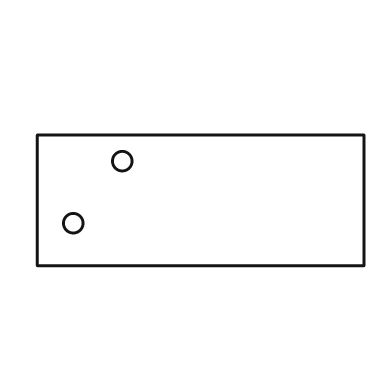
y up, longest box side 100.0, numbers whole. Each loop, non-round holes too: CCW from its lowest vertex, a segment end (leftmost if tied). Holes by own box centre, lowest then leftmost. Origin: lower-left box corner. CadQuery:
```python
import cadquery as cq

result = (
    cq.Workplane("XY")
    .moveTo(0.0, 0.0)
    .lineTo(100.0, 0.0)
    .lineTo(100.0, 40.0)
    .lineTo(0.0, 40.0)
    .close()
    .moveTo(11.0, 13.0)
    .circle(3.0)
    .moveTo(26.0, 32.0)
    .circle(3.0)
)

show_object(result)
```